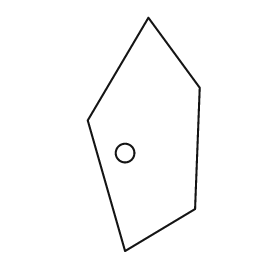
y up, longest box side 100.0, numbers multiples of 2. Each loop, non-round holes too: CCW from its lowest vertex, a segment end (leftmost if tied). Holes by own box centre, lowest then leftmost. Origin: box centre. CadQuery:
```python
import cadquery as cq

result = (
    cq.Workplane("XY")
    .moveTo(-8.0, -50.0)
    .lineTo(22.0, -32.0)
    .lineTo(24.0, 20.0)
    .lineTo(2.0, 50.0)
    .lineTo(-24.0, 6.0)
    .close()
    .moveTo(-8.0, -8.0)
    .circle(4.0)
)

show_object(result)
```